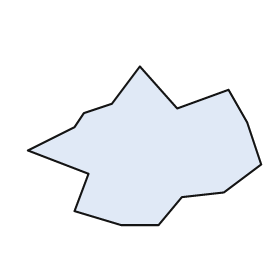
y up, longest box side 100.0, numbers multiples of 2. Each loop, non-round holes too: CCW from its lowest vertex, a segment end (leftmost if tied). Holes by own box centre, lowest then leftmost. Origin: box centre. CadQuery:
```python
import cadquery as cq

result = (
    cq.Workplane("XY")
    .moveTo(-10.0, -34.0)
    .lineTo(6.0, -34.0)
    .lineTo(16.0, -22.0)
    .lineTo(34.0, -20.0)
    .lineTo(50.0, -8.0)
    .lineTo(44.0, 10.0)
    .lineTo(36.0, 24.0)
    .lineTo(14.0, 16.0)
    .lineTo(-2.0, 34.0)
    .lineTo(-14.0, 18.0)
    .lineTo(-26.0, 14.0)
    .lineTo(-30.0, 8.0)
    .lineTo(-50.0, -2.0)
    .lineTo(-24.0, -12.0)
    .lineTo(-30.0, -28.0)
    .close()
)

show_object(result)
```